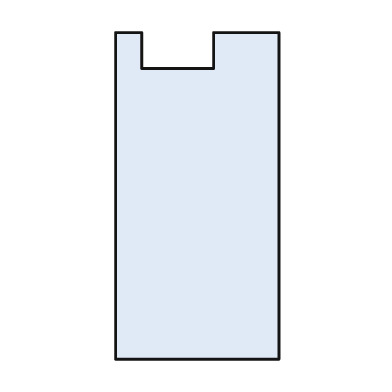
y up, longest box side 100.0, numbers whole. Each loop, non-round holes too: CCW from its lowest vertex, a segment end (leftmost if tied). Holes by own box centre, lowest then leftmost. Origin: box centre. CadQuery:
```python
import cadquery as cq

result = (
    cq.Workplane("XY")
    .moveTo(-25.0, -50.0)
    .lineTo(25.0, -50.0)
    .lineTo(25.0, 50.0)
    .lineTo(5.0, 50.0)
    .lineTo(5.0, 39.0)
    .lineTo(-17.0, 39.0)
    .lineTo(-17.0, 50.0)
    .lineTo(-25.0, 50.0)
    .close()
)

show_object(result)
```